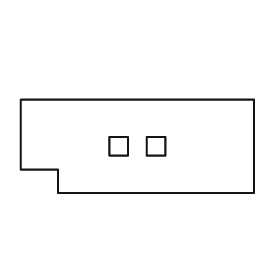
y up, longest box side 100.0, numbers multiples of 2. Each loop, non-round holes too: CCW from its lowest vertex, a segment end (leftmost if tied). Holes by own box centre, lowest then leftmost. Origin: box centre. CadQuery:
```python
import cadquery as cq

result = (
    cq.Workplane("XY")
    .moveTo(-34.0, -20.0)
    .lineTo(50.0, -20.0)
    .lineTo(50.0, 20.0)
    .lineTo(-50.0, 20.0)
    .lineTo(-50.0, -10.0)
    .lineTo(-34.0, -10.0)
    .close()
    .moveTo(-12.0, -4.0)
    .lineTo(-4.0, -4.0)
    .lineTo(-4.0, 4.0)
    .lineTo(-12.0, 4.0)
    .close()
    .moveTo(4.0, -4.0)
    .lineTo(12.0, -4.0)
    .lineTo(12.0, 4.0)
    .lineTo(4.0, 4.0)
    .close()
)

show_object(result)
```